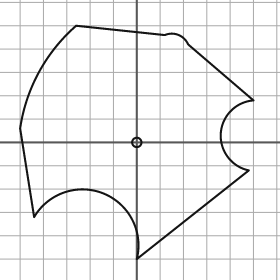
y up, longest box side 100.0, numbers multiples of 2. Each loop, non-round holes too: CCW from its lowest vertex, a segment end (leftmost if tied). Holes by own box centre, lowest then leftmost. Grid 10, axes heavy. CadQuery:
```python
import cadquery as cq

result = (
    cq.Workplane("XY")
    .moveTo(0.0, -50.0)
    .lineTo(48.0, -12.0)
    .threePointArc((36.0, 4.0), (50.0, 18.0))
    .lineTo(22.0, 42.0)
    .threePointArc((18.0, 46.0), (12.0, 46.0))
    .lineTo(-26.0, 50.0)
    .threePointArc((-42.0, 30.0), (-50.0, 6.0))
    .lineTo(-44.0, -32.0)
    .threePointArc((-14.0, -22.0), (0.0, -50.0))
    .close()
    .moveTo(0.0, 0.0)
    .circle(2.0)
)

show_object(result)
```